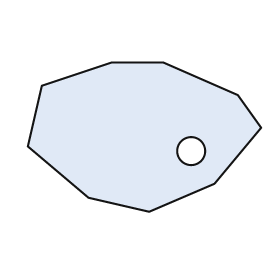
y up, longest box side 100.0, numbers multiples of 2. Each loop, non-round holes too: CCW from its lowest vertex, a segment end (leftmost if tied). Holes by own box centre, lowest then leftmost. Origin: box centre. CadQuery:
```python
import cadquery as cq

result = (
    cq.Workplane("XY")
    .moveTo(2.0, -32.0)
    .lineTo(30.0, -20.0)
    .lineTo(50.0, 4.0)
    .lineTo(40.0, 18.0)
    .lineTo(8.0, 32.0)
    .lineTo(-14.0, 32.0)
    .lineTo(-44.0, 22.0)
    .lineTo(-50.0, -4.0)
    .lineTo(-24.0, -26.0)
    .close()
    .moveTo(20.0, -6.0)
    .circle(6.0)
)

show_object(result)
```